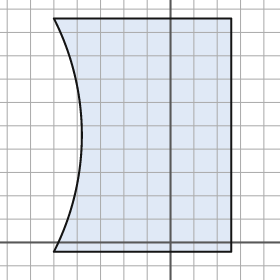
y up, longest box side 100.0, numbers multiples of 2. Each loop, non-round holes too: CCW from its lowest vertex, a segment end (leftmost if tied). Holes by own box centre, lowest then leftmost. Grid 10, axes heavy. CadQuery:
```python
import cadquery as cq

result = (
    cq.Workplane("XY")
    .moveTo(-50.0, -4.0)
    .lineTo(26.0, -4.0)
    .lineTo(26.0, 96.0)
    .lineTo(-50.0, 96.0)
    .threePointArc((-38.0, 46.0), (-50.0, -4.0))
    .close()
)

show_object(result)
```